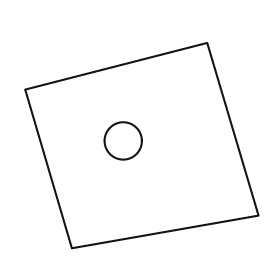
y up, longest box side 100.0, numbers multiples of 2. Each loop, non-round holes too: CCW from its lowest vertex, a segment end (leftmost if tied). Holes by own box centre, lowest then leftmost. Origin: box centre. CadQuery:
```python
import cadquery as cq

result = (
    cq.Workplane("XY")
    .moveTo(-30.0, -44.0)
    .lineTo(50.0, -30.0)
    .lineTo(28.0, 44.0)
    .lineTo(-50.0, 24.0)
    .close()
    .moveTo(-8.0, 2.0)
    .circle(8.0)
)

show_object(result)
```